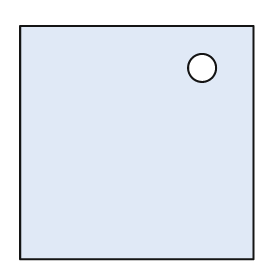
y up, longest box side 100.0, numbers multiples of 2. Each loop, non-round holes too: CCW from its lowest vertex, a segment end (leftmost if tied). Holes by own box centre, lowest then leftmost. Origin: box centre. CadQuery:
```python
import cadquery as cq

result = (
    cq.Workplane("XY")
    .moveTo(-50.0, -50.0)
    .lineTo(50.0, -50.0)
    .lineTo(50.0, 50.0)
    .lineTo(-50.0, 50.0)
    .close()
    .moveTo(28.0, 32.0)
    .circle(6.0)
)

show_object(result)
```